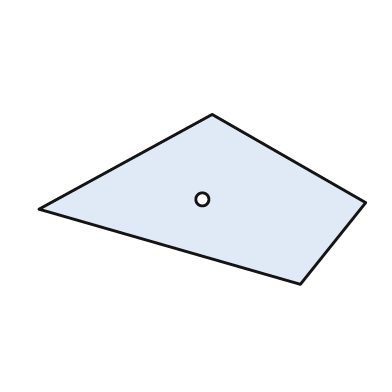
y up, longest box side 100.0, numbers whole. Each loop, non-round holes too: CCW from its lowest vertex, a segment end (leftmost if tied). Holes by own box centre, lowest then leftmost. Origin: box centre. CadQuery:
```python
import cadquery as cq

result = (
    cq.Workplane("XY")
    .moveTo(30.0, -26.0)
    .lineTo(50.0, -1.0)
    .lineTo(3.0, 26.0)
    .lineTo(-50.0, -3.0)
    .close()
    .moveTo(0.0, 0.0)
    .circle(2.0)
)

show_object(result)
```